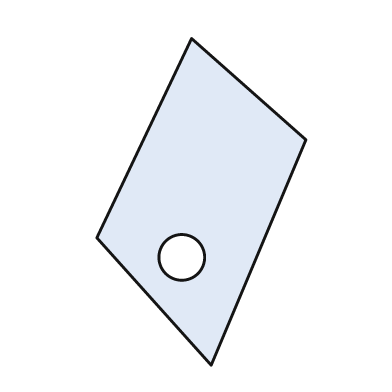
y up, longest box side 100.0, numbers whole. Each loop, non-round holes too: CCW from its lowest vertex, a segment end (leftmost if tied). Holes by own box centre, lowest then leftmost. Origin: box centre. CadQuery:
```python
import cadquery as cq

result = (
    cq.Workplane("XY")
    .moveTo(3.0, -50.0)
    .lineTo(32.0, 19.0)
    .lineTo(-3.0, 50.0)
    .lineTo(-32.0, -11.0)
    .close()
    .moveTo(-6.0, -17.0)
    .circle(7.0)
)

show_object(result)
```